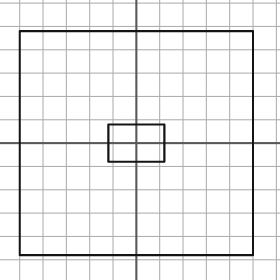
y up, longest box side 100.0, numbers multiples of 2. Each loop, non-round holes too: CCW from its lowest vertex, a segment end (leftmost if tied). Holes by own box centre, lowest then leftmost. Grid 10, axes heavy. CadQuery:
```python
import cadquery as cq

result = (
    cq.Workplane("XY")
    .moveTo(-50.0, -48.0)
    .lineTo(50.0, -48.0)
    .lineTo(50.0, 48.0)
    .lineTo(-50.0, 48.0)
    .close()
    .moveTo(-12.0, -8.0)
    .lineTo(12.0, -8.0)
    .lineTo(12.0, 8.0)
    .lineTo(-12.0, 8.0)
    .close()
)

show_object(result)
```